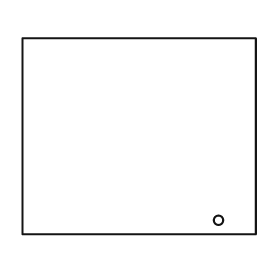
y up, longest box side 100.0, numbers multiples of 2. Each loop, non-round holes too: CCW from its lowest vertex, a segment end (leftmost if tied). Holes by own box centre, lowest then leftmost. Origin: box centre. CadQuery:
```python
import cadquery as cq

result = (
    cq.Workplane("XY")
    .moveTo(-50.0, -42.0)
    .lineTo(50.0, -42.0)
    .lineTo(50.0, 42.0)
    .lineTo(-50.0, 42.0)
    .close()
    .moveTo(34.0, -36.0)
    .circle(2.0)
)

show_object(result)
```